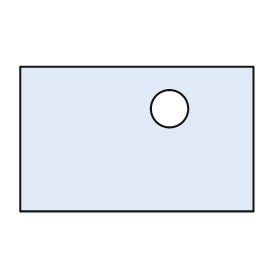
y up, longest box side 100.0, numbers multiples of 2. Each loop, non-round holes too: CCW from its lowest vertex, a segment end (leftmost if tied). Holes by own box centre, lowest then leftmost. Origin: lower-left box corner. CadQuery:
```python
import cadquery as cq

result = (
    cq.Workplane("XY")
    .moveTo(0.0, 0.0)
    .lineTo(100.0, 0.0)
    .lineTo(100.0, 62.0)
    .lineTo(0.0, 62.0)
    .close()
    .moveTo(64.0, 44.0)
    .circle(8.0)
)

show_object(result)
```